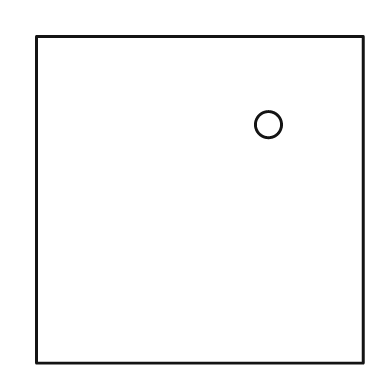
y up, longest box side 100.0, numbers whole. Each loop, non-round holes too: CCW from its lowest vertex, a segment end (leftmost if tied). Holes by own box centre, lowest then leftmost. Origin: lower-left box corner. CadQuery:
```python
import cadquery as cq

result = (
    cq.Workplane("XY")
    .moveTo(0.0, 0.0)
    .lineTo(100.0, 0.0)
    .lineTo(100.0, 100.0)
    .lineTo(0.0, 100.0)
    .close()
    .moveTo(71.0, 73.0)
    .circle(4.0)
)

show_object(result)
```